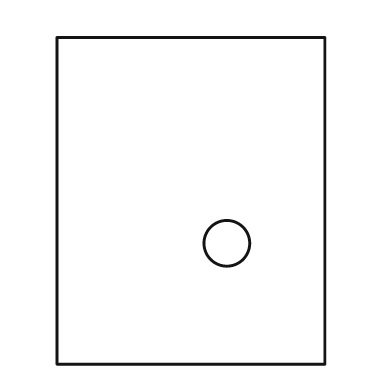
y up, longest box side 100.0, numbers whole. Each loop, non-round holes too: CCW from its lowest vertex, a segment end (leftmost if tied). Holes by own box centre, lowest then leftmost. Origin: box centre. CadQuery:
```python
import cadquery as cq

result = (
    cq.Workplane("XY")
    .moveTo(-41.0, -50.0)
    .lineTo(41.0, -50.0)
    .lineTo(41.0, 50.0)
    .lineTo(-41.0, 50.0)
    .close()
    .moveTo(11.0, -13.0)
    .circle(7.0)
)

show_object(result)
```